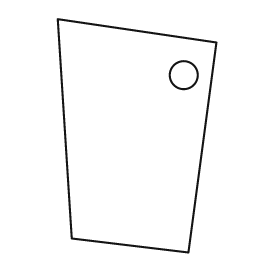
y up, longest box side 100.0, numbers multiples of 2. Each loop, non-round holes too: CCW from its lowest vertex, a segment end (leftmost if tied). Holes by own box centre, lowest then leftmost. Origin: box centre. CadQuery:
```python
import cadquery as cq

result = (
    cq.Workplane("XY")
    .moveTo(22.0, -50.0)
    .lineTo(34.0, 40.0)
    .lineTo(-34.0, 50.0)
    .lineTo(-28.0, -44.0)
    .close()
    .moveTo(20.0, 26.0)
    .circle(6.0)
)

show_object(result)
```